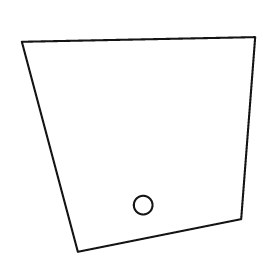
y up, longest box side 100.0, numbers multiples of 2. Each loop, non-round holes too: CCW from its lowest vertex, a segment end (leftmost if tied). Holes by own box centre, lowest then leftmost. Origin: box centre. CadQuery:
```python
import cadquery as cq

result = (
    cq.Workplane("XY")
    .moveTo(-26.0, -46.0)
    .lineTo(44.0, -32.0)
    .lineTo(50.0, 46.0)
    .lineTo(-50.0, 44.0)
    .close()
    .moveTo(2.0, -26.0)
    .circle(4.0)
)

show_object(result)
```